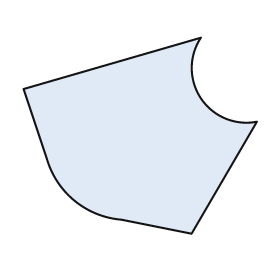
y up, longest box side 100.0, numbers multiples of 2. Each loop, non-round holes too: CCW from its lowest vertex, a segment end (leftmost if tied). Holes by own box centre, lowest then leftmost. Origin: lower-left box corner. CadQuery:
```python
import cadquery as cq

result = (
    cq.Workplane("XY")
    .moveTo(72.0, 0.0)
    .lineTo(100.0, 48.0)
    .threePointArc((76.0, 58.0), (76.0, 84.0))
    .lineTo(0.0, 62.0)
    .lineTo(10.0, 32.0)
    .threePointArc((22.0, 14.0), (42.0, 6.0))
    .close()
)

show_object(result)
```